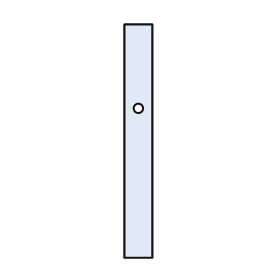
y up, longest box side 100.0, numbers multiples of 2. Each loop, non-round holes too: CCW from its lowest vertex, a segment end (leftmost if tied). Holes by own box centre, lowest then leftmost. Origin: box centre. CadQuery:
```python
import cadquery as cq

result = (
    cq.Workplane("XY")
    .moveTo(-6.0, -50.0)
    .lineTo(6.0, -50.0)
    .lineTo(6.0, 50.0)
    .lineTo(-6.0, 50.0)
    .close()
    .moveTo(0.0, 14.0)
    .circle(2.0)
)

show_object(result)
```